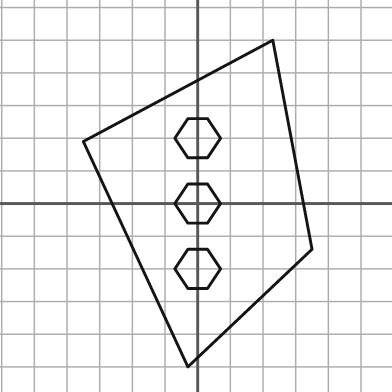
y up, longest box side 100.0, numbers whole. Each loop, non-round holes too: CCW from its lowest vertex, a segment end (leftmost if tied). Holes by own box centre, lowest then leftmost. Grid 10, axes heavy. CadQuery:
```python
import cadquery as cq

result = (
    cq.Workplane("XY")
    .moveTo(-3.0, -50.0)
    .lineTo(35.0, -14.0)
    .lineTo(23.0, 50.0)
    .lineTo(-35.0, 19.0)
    .close()
    .moveTo(-3.0, -26.0)
    .lineTo(3.0, -26.0)
    .lineTo(7.0, -20.0)
    .lineTo(3.0, -14.0)
    .lineTo(-3.0, -14.0)
    .lineTo(-7.0, -20.0)
    .close()
    .moveTo(-3.0, -6.0)
    .lineTo(3.0, -6.0)
    .lineTo(7.0, 0.0)
    .lineTo(3.0, 6.0)
    .lineTo(-3.0, 6.0)
    .lineTo(-7.0, 0.0)
    .close()
    .moveTo(-3.0, 14.0)
    .lineTo(3.0, 14.0)
    .lineTo(7.0, 20.0)
    .lineTo(3.0, 26.0)
    .lineTo(-3.0, 26.0)
    .lineTo(-7.0, 20.0)
    .close()
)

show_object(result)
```